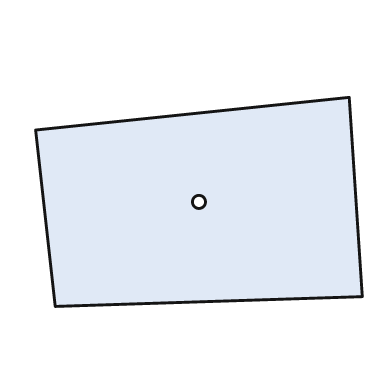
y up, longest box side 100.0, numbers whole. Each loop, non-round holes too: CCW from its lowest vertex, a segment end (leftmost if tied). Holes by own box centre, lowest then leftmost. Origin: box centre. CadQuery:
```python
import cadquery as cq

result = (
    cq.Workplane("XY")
    .moveTo(-44.0, -32.0)
    .lineTo(50.0, -29.0)
    .lineTo(46.0, 32.0)
    .lineTo(-50.0, 22.0)
    .close()
    .moveTo(0.0, 0.0)
    .circle(2.0)
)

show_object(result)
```